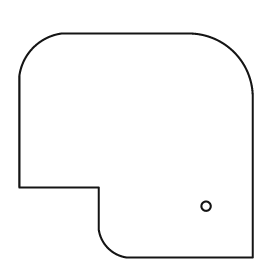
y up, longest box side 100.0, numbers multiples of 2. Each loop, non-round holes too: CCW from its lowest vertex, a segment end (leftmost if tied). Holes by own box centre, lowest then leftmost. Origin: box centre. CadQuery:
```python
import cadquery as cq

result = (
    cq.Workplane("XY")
    .moveTo(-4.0, -48.0)
    .lineTo(50.0, -48.0)
    .lineTo(50.0, 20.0)
    .threePointArc((42.0, 40.0), (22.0, 48.0))
    .lineTo(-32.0, 48.0)
    .threePointArc((-44.0, 42.0), (-50.0, 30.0))
    .lineTo(-50.0, -18.0)
    .lineTo(-16.0, -18.0)
    .lineTo(-16.0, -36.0)
    .threePointArc((-12.0, -44.0), (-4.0, -48.0))
    .close()
    .moveTo(30.0, -26.0)
    .circle(2.0)
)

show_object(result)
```